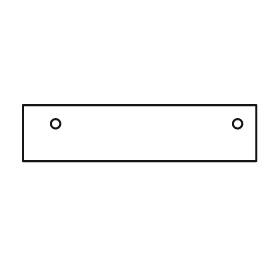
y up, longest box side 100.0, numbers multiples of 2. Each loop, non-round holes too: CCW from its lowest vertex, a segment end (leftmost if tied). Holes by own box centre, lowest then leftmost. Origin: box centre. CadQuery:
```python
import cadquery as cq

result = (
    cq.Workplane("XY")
    .moveTo(-50.0, -12.0)
    .lineTo(50.0, -12.0)
    .lineTo(50.0, 12.0)
    .lineTo(-50.0, 12.0)
    .close()
    .moveTo(-36.0, 4.0)
    .circle(2.0)
    .moveTo(42.0, 4.0)
    .circle(2.0)
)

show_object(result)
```